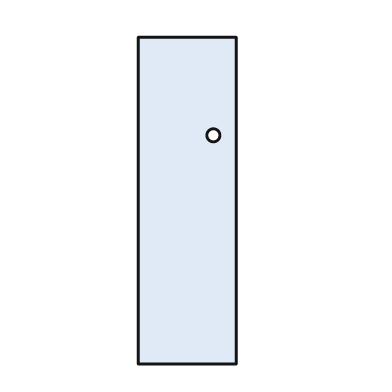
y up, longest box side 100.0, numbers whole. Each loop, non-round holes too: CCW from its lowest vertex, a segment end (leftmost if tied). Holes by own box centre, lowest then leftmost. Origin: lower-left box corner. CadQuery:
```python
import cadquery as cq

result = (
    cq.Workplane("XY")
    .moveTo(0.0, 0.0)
    .lineTo(30.0, 0.0)
    .lineTo(30.0, 100.0)
    .lineTo(0.0, 100.0)
    .close()
    .moveTo(23.0, 70.0)
    .circle(2.0)
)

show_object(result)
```